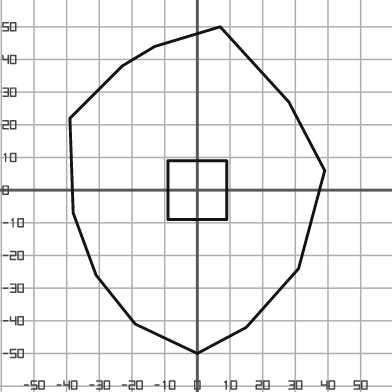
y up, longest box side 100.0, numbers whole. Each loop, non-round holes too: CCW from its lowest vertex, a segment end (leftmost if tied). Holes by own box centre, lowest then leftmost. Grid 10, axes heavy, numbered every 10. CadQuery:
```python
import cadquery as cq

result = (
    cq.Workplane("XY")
    .moveTo(0.0, -50.0)
    .lineTo(15.0, -42.0)
    .lineTo(31.0, -24.0)
    .lineTo(39.0, 6.0)
    .lineTo(28.0, 27.0)
    .lineTo(7.0, 50.0)
    .lineTo(-13.0, 44.0)
    .lineTo(-23.0, 38.0)
    .lineTo(-39.0, 22.0)
    .lineTo(-38.0, -7.0)
    .lineTo(-31.0, -26.0)
    .lineTo(-19.0, -41.0)
    .close()
    .moveTo(-9.0, -9.0)
    .lineTo(9.0, -9.0)
    .lineTo(9.0, 9.0)
    .lineTo(-9.0, 9.0)
    .close()
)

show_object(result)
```